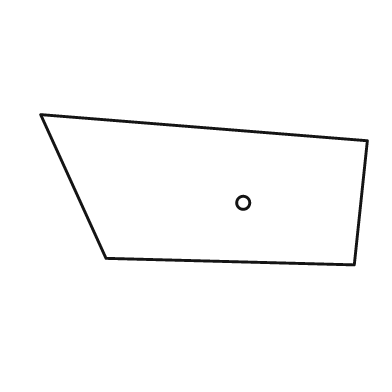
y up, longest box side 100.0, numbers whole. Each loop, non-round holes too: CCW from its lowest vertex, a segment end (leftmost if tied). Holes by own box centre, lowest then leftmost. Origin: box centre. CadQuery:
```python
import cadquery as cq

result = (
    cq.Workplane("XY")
    .moveTo(46.0, -23.0)
    .lineTo(50.0, 15.0)
    .lineTo(-50.0, 23.0)
    .lineTo(-30.0, -21.0)
    .close()
    .moveTo(12.0, -4.0)
    .circle(2.0)
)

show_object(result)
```